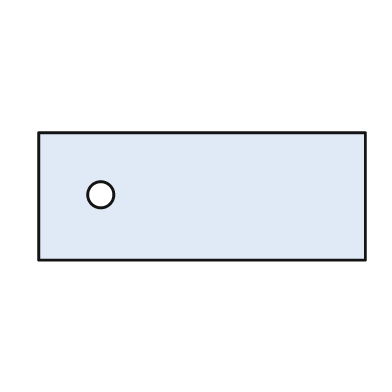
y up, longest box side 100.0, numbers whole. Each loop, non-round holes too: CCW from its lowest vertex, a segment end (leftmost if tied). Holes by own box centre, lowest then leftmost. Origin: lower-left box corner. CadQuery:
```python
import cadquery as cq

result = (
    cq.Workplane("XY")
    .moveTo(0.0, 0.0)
    .lineTo(100.0, 0.0)
    .lineTo(100.0, 39.0)
    .lineTo(0.0, 39.0)
    .close()
    .moveTo(19.0, 20.0)
    .circle(4.0)
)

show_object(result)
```